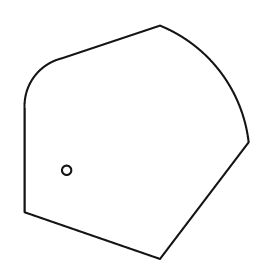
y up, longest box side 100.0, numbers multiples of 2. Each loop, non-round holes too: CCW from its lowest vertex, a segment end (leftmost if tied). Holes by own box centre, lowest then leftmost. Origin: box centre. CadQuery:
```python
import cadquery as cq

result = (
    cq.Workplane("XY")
    .moveTo(10.0, -50.0)
    .lineTo(48.0, 0.0)
    .threePointArc((36.0, 30.0), (10.0, 50.0))
    .lineTo(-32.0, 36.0)
    .threePointArc((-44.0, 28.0), (-48.0, 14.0))
    .lineTo(-48.0, -30.0)
    .close()
    .moveTo(-30.0, -12.0)
    .circle(2.0)
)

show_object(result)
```